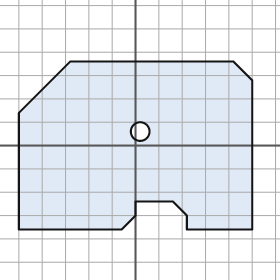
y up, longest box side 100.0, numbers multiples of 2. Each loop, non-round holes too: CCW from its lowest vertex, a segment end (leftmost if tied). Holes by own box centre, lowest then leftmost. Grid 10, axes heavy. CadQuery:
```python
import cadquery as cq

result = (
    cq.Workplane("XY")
    .moveTo(-50.0, -36.0)
    .lineTo(-6.0, -36.0)
    .lineTo(0.0, -30.0)
    .lineTo(0.0, -24.0)
    .lineTo(16.0, -24.0)
    .lineTo(22.0, -30.0)
    .lineTo(22.0, -36.0)
    .lineTo(50.0, -36.0)
    .lineTo(50.0, 28.0)
    .lineTo(42.0, 36.0)
    .lineTo(-28.0, 36.0)
    .lineTo(-50.0, 14.0)
    .close()
    .moveTo(2.0, 6.0)
    .circle(4.0)
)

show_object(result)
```